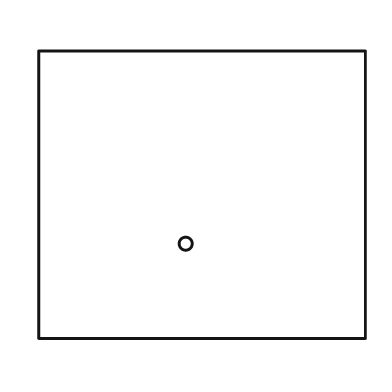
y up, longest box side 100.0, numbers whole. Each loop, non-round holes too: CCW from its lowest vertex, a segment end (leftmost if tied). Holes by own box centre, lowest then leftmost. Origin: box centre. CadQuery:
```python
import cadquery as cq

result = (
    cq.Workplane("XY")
    .moveTo(-50.0, -44.0)
    .lineTo(50.0, -44.0)
    .lineTo(50.0, 44.0)
    .lineTo(-50.0, 44.0)
    .close()
    .moveTo(-5.0, -15.0)
    .circle(2.0)
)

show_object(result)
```